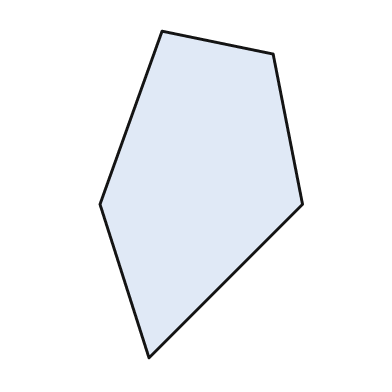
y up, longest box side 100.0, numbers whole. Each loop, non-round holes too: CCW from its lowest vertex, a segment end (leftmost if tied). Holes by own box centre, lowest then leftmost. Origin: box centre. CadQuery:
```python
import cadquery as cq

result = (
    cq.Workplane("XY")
    .moveTo(-16.0, -50.0)
    .lineTo(31.0, -3.0)
    .lineTo(22.0, 43.0)
    .lineTo(-12.0, 50.0)
    .lineTo(-31.0, -3.0)
    .close()
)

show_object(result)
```